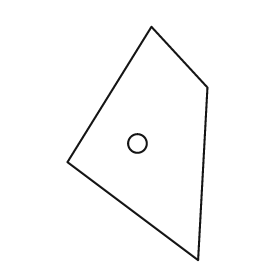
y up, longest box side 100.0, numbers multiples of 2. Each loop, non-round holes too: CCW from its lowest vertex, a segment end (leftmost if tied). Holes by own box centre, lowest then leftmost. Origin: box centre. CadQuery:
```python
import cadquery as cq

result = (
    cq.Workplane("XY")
    .moveTo(26.0, -50.0)
    .lineTo(30.0, 24.0)
    .lineTo(6.0, 50.0)
    .lineTo(-30.0, -8.0)
    .close()
    .moveTo(0.0, 0.0)
    .circle(4.0)
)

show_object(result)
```